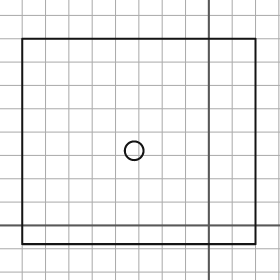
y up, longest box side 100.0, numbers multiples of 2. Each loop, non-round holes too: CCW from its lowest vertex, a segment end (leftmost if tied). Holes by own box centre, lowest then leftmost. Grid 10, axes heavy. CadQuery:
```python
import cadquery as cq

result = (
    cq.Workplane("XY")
    .moveTo(-80.0, -8.0)
    .lineTo(20.0, -8.0)
    .lineTo(20.0, 80.0)
    .lineTo(-80.0, 80.0)
    .close()
    .moveTo(-32.0, 32.0)
    .circle(4.0)
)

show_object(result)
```